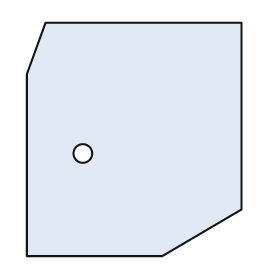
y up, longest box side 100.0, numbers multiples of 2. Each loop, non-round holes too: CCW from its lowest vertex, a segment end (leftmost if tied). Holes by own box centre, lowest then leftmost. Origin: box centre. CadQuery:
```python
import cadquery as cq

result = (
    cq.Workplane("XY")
    .moveTo(-46.0, -50.0)
    .lineTo(12.0, -50.0)
    .lineTo(46.0, -30.0)
    .lineTo(46.0, 50.0)
    .lineTo(-38.0, 50.0)
    .lineTo(-46.0, 28.0)
    .close()
    .moveTo(-22.0, -6.0)
    .circle(4.0)
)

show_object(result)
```